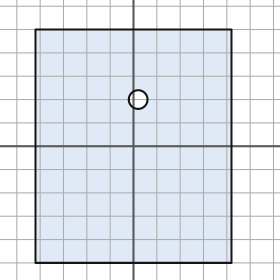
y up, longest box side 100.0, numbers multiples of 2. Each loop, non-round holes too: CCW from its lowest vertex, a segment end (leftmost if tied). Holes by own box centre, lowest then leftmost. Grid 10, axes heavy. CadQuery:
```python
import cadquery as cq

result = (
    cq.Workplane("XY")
    .moveTo(-42.0, -50.0)
    .lineTo(42.0, -50.0)
    .lineTo(42.0, 50.0)
    .lineTo(-42.0, 50.0)
    .close()
    .moveTo(2.0, 20.0)
    .circle(4.0)
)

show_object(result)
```